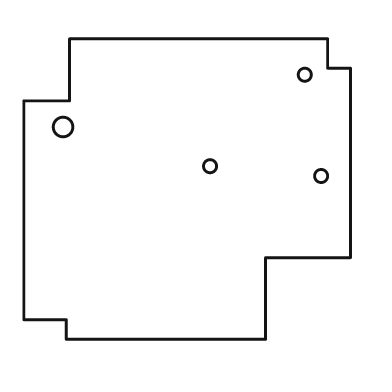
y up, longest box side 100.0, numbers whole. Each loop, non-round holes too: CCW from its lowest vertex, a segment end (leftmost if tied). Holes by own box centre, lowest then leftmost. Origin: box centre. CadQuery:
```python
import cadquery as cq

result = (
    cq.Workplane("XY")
    .moveTo(-37.0, -46.0)
    .lineTo(24.0, -46.0)
    .lineTo(24.0, -21.0)
    .lineTo(50.0, -21.0)
    .lineTo(50.0, 37.0)
    .lineTo(43.0, 37.0)
    .lineTo(43.0, 46.0)
    .lineTo(-36.0, 46.0)
    .lineTo(-36.0, 27.0)
    .lineTo(-50.0, 27.0)
    .lineTo(-50.0, -40.0)
    .lineTo(-37.0, -40.0)
    .close()
    .moveTo(41.0, 4.0)
    .circle(2.0)
    .moveTo(7.0, 7.0)
    .circle(2.0)
    .moveTo(-38.0, 19.0)
    .circle(3.0)
    .moveTo(36.0, 35.0)
    .circle(2.0)
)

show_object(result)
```